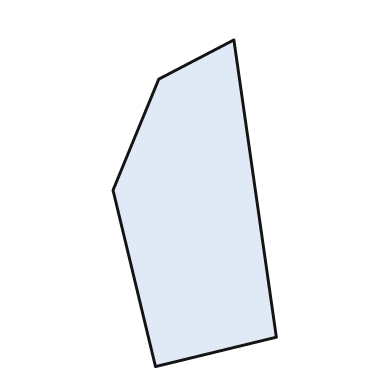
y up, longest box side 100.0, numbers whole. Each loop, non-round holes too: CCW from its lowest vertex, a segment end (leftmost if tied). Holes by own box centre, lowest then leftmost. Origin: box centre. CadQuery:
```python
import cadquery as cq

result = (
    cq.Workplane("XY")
    .moveTo(-12.0, -50.0)
    .lineTo(25.0, -41.0)
    .lineTo(12.0, 50.0)
    .lineTo(-11.0, 38.0)
    .lineTo(-25.0, 4.0)
    .close()
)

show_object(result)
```